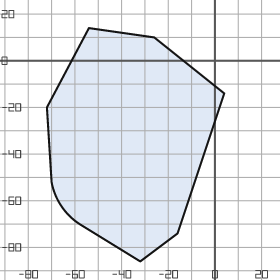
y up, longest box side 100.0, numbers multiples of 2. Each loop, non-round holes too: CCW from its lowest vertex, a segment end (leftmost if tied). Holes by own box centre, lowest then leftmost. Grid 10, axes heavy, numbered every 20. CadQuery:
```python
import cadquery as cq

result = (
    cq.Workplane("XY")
    .moveTo(-32.0, -86.0)
    .lineTo(-16.0, -74.0)
    .lineTo(4.0, -14.0)
    .lineTo(-26.0, 10.0)
    .lineTo(-54.0, 14.0)
    .lineTo(-72.0, -20.0)
    .lineTo(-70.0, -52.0)
    .threePointArc((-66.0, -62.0), (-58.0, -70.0))
    .close()
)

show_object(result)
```